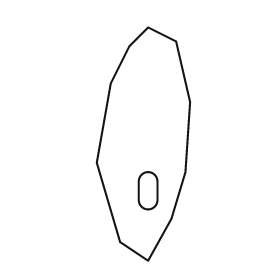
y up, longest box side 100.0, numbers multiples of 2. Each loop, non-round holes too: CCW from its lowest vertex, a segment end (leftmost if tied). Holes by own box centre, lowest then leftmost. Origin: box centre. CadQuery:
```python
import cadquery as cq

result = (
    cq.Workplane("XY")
    .moveTo(2.0, -50.0)
    .lineTo(12.0, -32.0)
    .lineTo(18.0, -12.0)
    .lineTo(20.0, 18.0)
    .lineTo(14.0, 44.0)
    .lineTo(2.0, 50.0)
    .lineTo(-6.0, 42.0)
    .lineTo(-14.0, 26.0)
    .lineTo(-20.0, -8.0)
    .lineTo(-10.0, -42.0)
    .close()
    .moveTo(-2.0, -24.0)
    .threePointArc((2.0, -28.0), (6.0, -24.0))
    .lineTo(6.0, -16.0)
    .threePointArc((2.0, -12.0), (-2.0, -16.0))
    .close()
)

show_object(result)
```